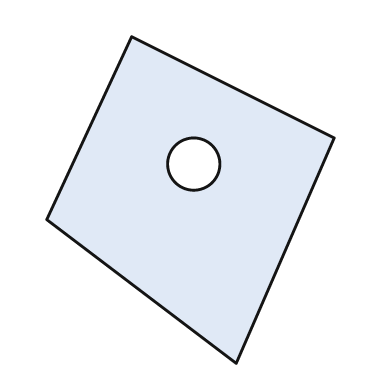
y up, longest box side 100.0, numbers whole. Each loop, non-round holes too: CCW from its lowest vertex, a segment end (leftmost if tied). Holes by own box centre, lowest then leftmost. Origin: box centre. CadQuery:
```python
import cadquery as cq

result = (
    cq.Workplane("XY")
    .moveTo(14.0, -50.0)
    .lineTo(44.0, 19.0)
    .lineTo(-18.0, 50.0)
    .lineTo(-44.0, -6.0)
    .close()
    .moveTo(1.0, 11.0)
    .circle(8.0)
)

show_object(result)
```